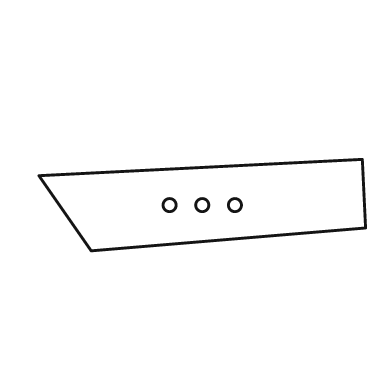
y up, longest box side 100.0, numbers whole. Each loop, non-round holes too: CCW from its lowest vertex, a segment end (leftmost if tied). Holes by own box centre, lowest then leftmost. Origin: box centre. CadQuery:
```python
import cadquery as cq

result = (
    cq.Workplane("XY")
    .moveTo(-34.0, -14.0)
    .lineTo(50.0, -7.0)
    .lineTo(49.0, 14.0)
    .lineTo(-50.0, 9.0)
    .close()
    .moveTo(-10.0, 0.0)
    .circle(2.0)
    .moveTo(0.0, 0.0)
    .circle(2.0)
    .moveTo(10.0, 0.0)
    .circle(2.0)
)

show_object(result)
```